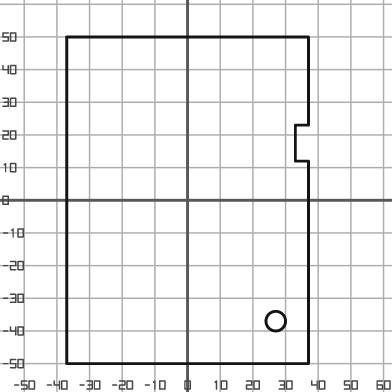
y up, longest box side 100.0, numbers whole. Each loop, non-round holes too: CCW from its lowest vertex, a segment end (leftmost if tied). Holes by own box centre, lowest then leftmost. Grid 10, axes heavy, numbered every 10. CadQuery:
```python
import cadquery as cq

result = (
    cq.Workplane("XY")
    .moveTo(-37.0, -50.0)
    .lineTo(37.0, -50.0)
    .lineTo(37.0, 12.0)
    .lineTo(33.0, 12.0)
    .lineTo(33.0, 23.0)
    .lineTo(37.0, 23.0)
    .lineTo(37.0, 50.0)
    .lineTo(-37.0, 50.0)
    .close()
    .moveTo(27.0, -37.0)
    .circle(3.0)
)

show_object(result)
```